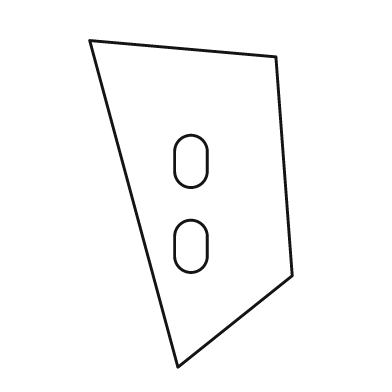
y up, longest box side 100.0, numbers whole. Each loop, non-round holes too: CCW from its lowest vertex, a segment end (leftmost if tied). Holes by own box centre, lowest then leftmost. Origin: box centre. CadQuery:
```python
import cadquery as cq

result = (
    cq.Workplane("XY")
    .moveTo(-4.0, -50.0)
    .lineTo(31.0, -22.0)
    .lineTo(26.0, 45.0)
    .lineTo(-31.0, 50.0)
    .close()
    .moveTo(-5.0, -16.0)
    .threePointArc((0.0, -21.0), (5.0, -16.0))
    .lineTo(5.0, -10.0)
    .threePointArc((0.0, -5.0), (-5.0, -10.0))
    .close()
    .moveTo(-5.0, 10.0)
    .threePointArc((0.0, 5.0), (5.0, 10.0))
    .lineTo(5.0, 16.0)
    .threePointArc((0.0, 21.0), (-5.0, 16.0))
    .close()
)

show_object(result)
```